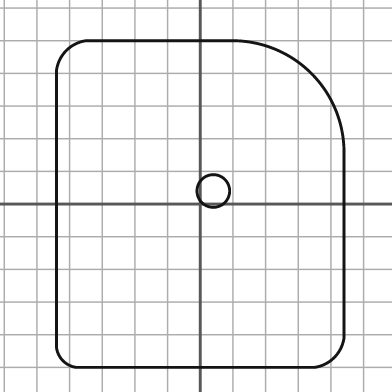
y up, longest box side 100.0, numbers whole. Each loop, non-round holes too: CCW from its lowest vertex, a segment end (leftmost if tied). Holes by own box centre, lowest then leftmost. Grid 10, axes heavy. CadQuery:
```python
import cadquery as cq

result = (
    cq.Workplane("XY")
    .moveTo(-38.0, -50.0)
    .lineTo(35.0, -50.0)
    .threePointArc((41.0, -47.0), (44.0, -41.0))
    .lineTo(44.0, 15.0)
    .threePointArc((34.0, 40.0), (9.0, 50.0))
    .lineTo(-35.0, 50.0)
    .threePointArc((-41.0, 47.0), (-44.0, 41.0))
    .lineTo(-44.0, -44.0)
    .threePointArc((-42.0, -48.0), (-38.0, -50.0))
    .close()
    .moveTo(4.0, 4.0)
    .circle(5.0)
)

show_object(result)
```